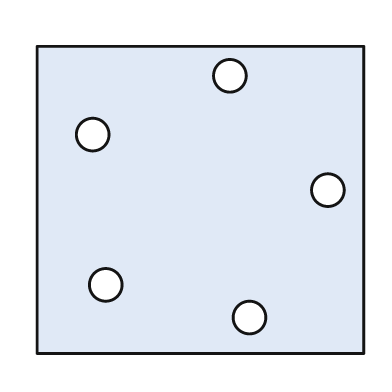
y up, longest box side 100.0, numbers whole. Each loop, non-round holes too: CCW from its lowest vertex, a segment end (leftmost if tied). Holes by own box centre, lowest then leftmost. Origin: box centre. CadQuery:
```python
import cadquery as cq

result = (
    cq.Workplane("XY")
    .moveTo(-50.0, -47.0)
    .lineTo(50.0, -47.0)
    .lineTo(50.0, 47.0)
    .lineTo(-50.0, 47.0)
    .close()
    .moveTo(15.0, -36.0)
    .circle(5.0)
    .moveTo(-29.0, -26.0)
    .circle(5.0)
    .moveTo(39.0, 3.0)
    .circle(5.0)
    .moveTo(-33.0, 20.0)
    .circle(5.0)
    .moveTo(9.0, 38.0)
    .circle(5.0)
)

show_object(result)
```